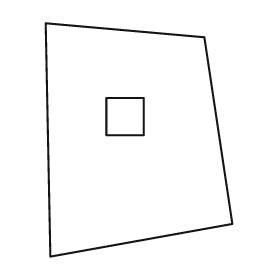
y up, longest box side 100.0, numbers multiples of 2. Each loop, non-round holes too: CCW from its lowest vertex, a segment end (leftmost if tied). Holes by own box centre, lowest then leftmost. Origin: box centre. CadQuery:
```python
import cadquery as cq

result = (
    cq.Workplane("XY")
    .moveTo(-38.0, -50.0)
    .lineTo(40.0, -36.0)
    .lineTo(28.0, 44.0)
    .lineTo(-40.0, 50.0)
    .close()
    .moveTo(-14.0, 2.0)
    .lineTo(2.0, 2.0)
    .lineTo(2.0, 18.0)
    .lineTo(-14.0, 18.0)
    .close()
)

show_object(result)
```